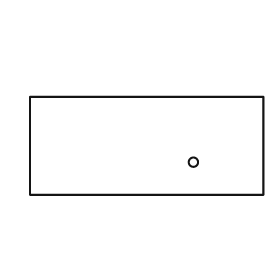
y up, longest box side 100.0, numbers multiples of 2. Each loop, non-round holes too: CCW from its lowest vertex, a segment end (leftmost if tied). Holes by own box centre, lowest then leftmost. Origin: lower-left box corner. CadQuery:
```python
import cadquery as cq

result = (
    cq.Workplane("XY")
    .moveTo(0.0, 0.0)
    .lineTo(100.0, 0.0)
    .lineTo(100.0, 42.0)
    .lineTo(0.0, 42.0)
    .close()
    .moveTo(70.0, 14.0)
    .circle(2.0)
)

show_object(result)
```